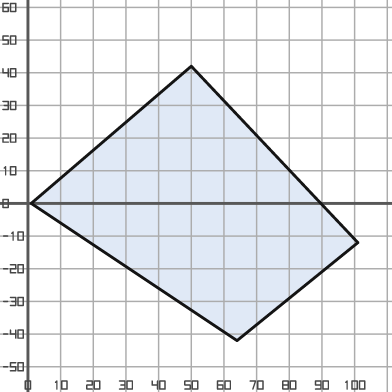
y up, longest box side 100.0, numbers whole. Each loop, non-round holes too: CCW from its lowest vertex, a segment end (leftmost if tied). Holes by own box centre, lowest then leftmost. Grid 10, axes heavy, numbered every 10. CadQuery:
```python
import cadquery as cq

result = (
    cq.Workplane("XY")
    .moveTo(64.0, -42.0)
    .lineTo(101.0, -12.0)
    .lineTo(50.0, 42.0)
    .lineTo(1.0, 0.0)
    .close()
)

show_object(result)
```